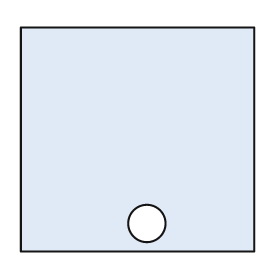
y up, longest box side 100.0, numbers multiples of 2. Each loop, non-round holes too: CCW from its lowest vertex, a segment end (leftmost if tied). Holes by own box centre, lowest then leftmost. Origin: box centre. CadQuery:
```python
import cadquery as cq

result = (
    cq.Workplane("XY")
    .moveTo(-50.0, -48.0)
    .lineTo(50.0, -48.0)
    .lineTo(50.0, 48.0)
    .lineTo(-50.0, 48.0)
    .close()
    .moveTo(4.0, -36.0)
    .circle(8.0)
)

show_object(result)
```